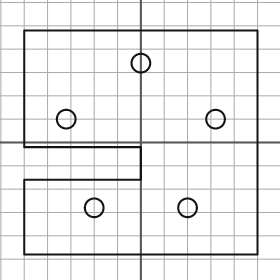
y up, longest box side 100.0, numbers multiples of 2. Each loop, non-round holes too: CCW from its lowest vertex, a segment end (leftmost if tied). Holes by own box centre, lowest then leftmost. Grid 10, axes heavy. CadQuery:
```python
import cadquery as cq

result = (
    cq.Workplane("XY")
    .moveTo(-50.0, -48.0)
    .lineTo(50.0, -48.0)
    .lineTo(50.0, 48.0)
    .lineTo(-50.0, 48.0)
    .lineTo(-50.0, -2.0)
    .lineTo(0.0, -2.0)
    .lineTo(0.0, -16.0)
    .lineTo(-50.0, -16.0)
    .close()
    .moveTo(-20.0, -28.0)
    .circle(4.0)
    .moveTo(20.0, -28.0)
    .circle(4.0)
    .moveTo(-32.0, 10.0)
    .circle(4.0)
    .moveTo(32.0, 10.0)
    .circle(4.0)
    .moveTo(0.0, 34.0)
    .circle(4.0)
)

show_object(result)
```